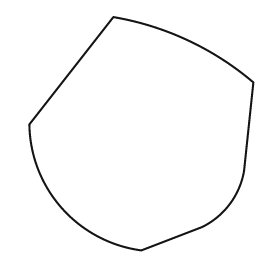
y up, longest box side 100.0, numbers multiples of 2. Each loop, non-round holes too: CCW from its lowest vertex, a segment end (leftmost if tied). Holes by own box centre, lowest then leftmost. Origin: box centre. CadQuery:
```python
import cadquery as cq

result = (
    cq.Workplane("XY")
    .moveTo(0.0, -50.0)
    .lineTo(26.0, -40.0)
    .threePointArc((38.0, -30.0), (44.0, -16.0))
    .lineTo(48.0, 22.0)
    .threePointArc((20.0, 40.0), (-12.0, 50.0))
    .lineTo(-48.0, 4.0)
    .threePointArc((-34.0, -32.0), (0.0, -50.0))
    .close()
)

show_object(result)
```